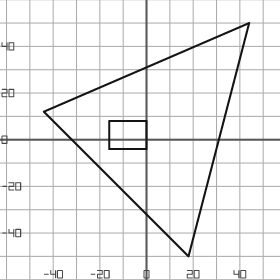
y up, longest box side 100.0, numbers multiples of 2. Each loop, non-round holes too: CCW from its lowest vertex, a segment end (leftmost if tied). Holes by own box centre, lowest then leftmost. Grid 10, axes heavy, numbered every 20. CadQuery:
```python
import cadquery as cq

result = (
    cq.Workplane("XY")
    .moveTo(18.0, -50.0)
    .lineTo(44.0, 50.0)
    .lineTo(-44.0, 12.0)
    .close()
    .moveTo(-16.0, -4.0)
    .lineTo(0.0, -4.0)
    .lineTo(0.0, 8.0)
    .lineTo(-16.0, 8.0)
    .close()
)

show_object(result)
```